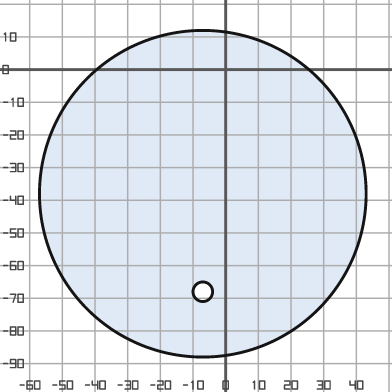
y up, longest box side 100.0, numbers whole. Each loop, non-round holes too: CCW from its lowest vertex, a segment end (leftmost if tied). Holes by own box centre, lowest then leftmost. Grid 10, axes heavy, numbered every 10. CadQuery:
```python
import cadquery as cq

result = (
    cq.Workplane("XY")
    .moveTo(-7.0, -38.0)
    .circle(50.0)
    .moveTo(-7.0, -68.0)
    .circle(3.0)
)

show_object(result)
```